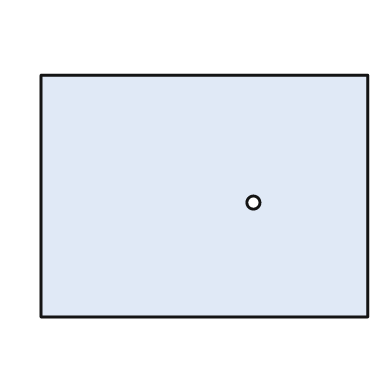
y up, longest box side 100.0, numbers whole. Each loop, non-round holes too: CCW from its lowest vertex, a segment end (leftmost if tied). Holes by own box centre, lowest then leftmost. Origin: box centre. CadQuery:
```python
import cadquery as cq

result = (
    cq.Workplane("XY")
    .moveTo(-50.0, -37.0)
    .lineTo(50.0, -37.0)
    .lineTo(50.0, 37.0)
    .lineTo(-50.0, 37.0)
    .close()
    .moveTo(15.0, -2.0)
    .circle(2.0)
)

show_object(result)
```